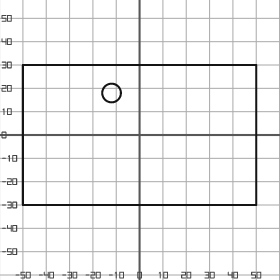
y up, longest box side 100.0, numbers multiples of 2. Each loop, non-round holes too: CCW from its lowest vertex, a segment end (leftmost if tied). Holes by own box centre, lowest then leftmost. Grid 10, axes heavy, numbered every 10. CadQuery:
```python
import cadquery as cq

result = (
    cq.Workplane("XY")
    .moveTo(-50.0, -30.0)
    .lineTo(50.0, -30.0)
    .lineTo(50.0, 30.0)
    .lineTo(-50.0, 30.0)
    .close()
    .moveTo(-12.0, 18.0)
    .circle(4.0)
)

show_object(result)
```